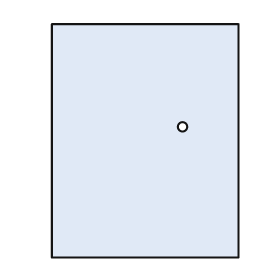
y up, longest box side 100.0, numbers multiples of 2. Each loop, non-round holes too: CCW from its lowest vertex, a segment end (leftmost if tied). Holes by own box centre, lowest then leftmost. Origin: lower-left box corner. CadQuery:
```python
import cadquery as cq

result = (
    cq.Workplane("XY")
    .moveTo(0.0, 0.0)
    .lineTo(80.0, 0.0)
    .lineTo(80.0, 100.0)
    .lineTo(0.0, 100.0)
    .close()
    .moveTo(56.0, 56.0)
    .circle(2.0)
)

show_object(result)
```